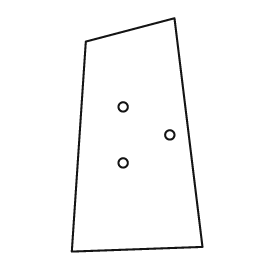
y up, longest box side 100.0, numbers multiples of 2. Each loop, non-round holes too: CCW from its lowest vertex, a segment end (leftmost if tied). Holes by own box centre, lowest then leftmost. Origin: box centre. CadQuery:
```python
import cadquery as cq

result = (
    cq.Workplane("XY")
    .moveTo(-28.0, -50.0)
    .lineTo(28.0, -48.0)
    .lineTo(16.0, 50.0)
    .lineTo(-22.0, 40.0)
    .close()
    .moveTo(-6.0, -12.0)
    .circle(2.0)
    .moveTo(14.0, 0.0)
    .circle(2.0)
    .moveTo(-6.0, 12.0)
    .circle(2.0)
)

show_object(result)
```